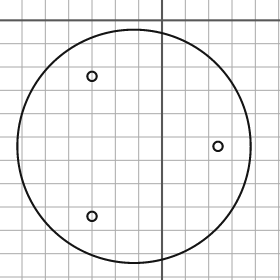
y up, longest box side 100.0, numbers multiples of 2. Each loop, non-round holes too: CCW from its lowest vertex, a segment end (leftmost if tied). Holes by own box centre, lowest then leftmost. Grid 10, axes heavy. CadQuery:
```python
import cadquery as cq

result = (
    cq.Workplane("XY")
    .moveTo(-12.0, -54.0)
    .circle(50.0)
    .moveTo(-30.0, -84.0)
    .circle(2.0)
    .moveTo(24.0, -54.0)
    .circle(2.0)
    .moveTo(-30.0, -24.0)
    .circle(2.0)
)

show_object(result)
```